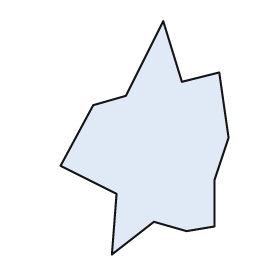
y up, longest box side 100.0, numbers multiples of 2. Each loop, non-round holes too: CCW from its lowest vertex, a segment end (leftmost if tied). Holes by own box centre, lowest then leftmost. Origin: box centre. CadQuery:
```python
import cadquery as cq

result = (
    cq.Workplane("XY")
    .moveTo(-14.0, -50.0)
    .lineTo(4.0, -36.0)
    .lineTo(18.0, -40.0)
    .lineTo(30.0, -38.0)
    .lineTo(30.0, -18.0)
    .lineTo(36.0, 0.0)
    .lineTo(32.0, 28.0)
    .lineTo(16.0, 24.0)
    .lineTo(8.0, 50.0)
    .lineTo(-8.0, 18.0)
    .lineTo(-22.0, 14.0)
    .lineTo(-36.0, -12.0)
    .lineTo(-12.0, -24.0)
    .close()
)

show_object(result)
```